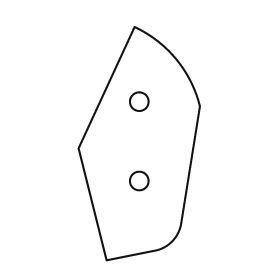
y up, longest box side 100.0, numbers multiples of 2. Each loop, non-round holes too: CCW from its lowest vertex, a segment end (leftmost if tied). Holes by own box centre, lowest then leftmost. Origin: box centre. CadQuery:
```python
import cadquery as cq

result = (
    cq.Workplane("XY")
    .moveTo(-14.0, -50.0)
    .lineTo(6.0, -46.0)
    .threePointArc((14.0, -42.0), (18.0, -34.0))
    .lineTo(26.0, 16.0)
    .threePointArc((16.0, 36.0), (-2.0, 50.0))
    .lineTo(-26.0, -2.0)
    .close()
    .moveTo(0.0, -16.0)
    .circle(4.0)
    .moveTo(0.0, 18.0)
    .circle(4.0)
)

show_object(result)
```